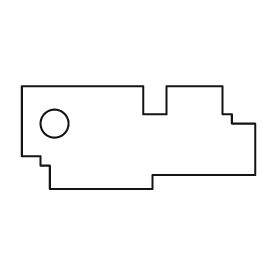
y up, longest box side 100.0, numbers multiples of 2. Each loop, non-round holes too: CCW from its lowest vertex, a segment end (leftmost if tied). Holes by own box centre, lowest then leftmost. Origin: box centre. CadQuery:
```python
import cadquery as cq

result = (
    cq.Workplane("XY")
    .moveTo(-38.0, -22.0)
    .lineTo(6.0, -22.0)
    .lineTo(6.0, -16.0)
    .lineTo(50.0, -16.0)
    .lineTo(50.0, 6.0)
    .lineTo(40.0, 6.0)
    .lineTo(40.0, 10.0)
    .lineTo(36.0, 10.0)
    .lineTo(36.0, 22.0)
    .lineTo(12.0, 22.0)
    .lineTo(12.0, 10.0)
    .lineTo(2.0, 10.0)
    .lineTo(2.0, 22.0)
    .lineTo(-50.0, 22.0)
    .lineTo(-50.0, -8.0)
    .lineTo(-42.0, -8.0)
    .lineTo(-42.0, -12.0)
    .lineTo(-38.0, -12.0)
    .close()
    .moveTo(-36.0, 6.0)
    .circle(6.0)
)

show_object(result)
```